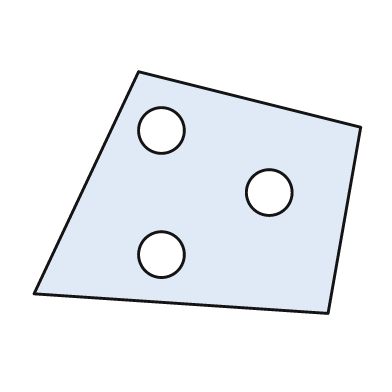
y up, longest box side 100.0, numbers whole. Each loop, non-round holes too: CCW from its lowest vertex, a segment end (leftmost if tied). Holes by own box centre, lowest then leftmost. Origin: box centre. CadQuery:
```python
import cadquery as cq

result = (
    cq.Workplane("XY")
    .moveTo(40.0, -37.0)
    .lineTo(50.0, 20.0)
    .lineTo(-18.0, 37.0)
    .lineTo(-50.0, -31.0)
    .close()
    .moveTo(-11.0, -19.0)
    .circle(7.0)
    .moveTo(22.0, 0.0)
    .circle(7.0)
    .moveTo(-11.0, 19.0)
    .circle(7.0)
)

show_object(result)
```